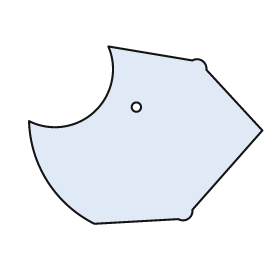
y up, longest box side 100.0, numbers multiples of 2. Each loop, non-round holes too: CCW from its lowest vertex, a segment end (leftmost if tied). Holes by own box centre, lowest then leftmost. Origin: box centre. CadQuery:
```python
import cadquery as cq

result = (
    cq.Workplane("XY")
    .moveTo(-22.0, -38.0)
    .lineTo(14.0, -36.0)
    .threePointArc((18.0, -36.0), (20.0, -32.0))
    .lineTo(50.0, 2.0)
    .lineTo(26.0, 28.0)
    .threePointArc((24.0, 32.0), (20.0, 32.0))
    .lineTo(-16.0, 38.0)
    .threePointArc((-22.0, 10.0), (-50.0, 6.0))
    .threePointArc((-42.0, -20.0), (-22.0, -38.0))
    .close()
    .moveTo(-4.0, 12.0)
    .circle(2.0)
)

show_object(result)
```